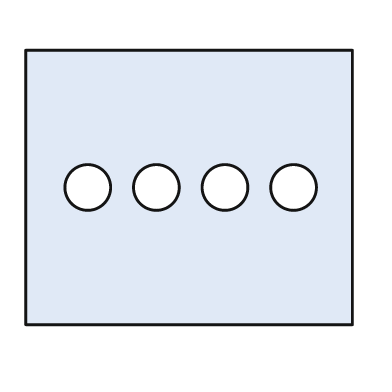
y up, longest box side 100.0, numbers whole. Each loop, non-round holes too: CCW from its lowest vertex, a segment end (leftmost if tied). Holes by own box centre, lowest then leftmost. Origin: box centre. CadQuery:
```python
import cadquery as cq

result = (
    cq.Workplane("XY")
    .moveTo(-50.0, -42.0)
    .lineTo(50.0, -42.0)
    .lineTo(50.0, 42.0)
    .lineTo(-50.0, 42.0)
    .close()
    .moveTo(-31.0, 0.0)
    .circle(7.0)
    .moveTo(-10.0, 0.0)
    .circle(7.0)
    .moveTo(11.0, 0.0)
    .circle(7.0)
    .moveTo(32.0, 0.0)
    .circle(7.0)
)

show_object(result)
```